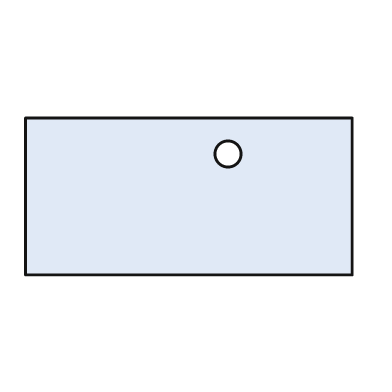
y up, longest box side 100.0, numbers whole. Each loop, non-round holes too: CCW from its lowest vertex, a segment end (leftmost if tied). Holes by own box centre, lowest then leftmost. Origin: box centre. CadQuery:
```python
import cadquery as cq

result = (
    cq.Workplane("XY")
    .moveTo(-50.0, -24.0)
    .lineTo(50.0, -24.0)
    .lineTo(50.0, 24.0)
    .lineTo(-50.0, 24.0)
    .close()
    .moveTo(12.0, 13.0)
    .circle(4.0)
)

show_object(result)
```